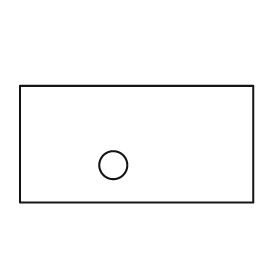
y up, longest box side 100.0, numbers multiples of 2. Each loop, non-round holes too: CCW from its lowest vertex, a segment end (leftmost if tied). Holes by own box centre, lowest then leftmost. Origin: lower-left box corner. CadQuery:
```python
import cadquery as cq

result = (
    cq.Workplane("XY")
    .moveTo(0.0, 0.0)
    .lineTo(100.0, 0.0)
    .lineTo(100.0, 50.0)
    .lineTo(0.0, 50.0)
    .close()
    .moveTo(40.0, 16.0)
    .circle(6.0)
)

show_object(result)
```